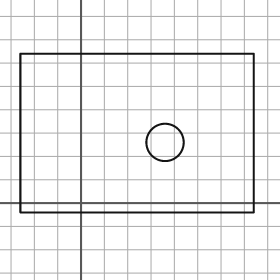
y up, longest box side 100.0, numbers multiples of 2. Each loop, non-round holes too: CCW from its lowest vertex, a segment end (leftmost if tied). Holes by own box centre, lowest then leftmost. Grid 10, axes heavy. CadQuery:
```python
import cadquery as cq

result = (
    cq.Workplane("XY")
    .moveTo(-26.0, -4.0)
    .lineTo(74.0, -4.0)
    .lineTo(74.0, 64.0)
    .lineTo(-26.0, 64.0)
    .close()
    .moveTo(36.0, 26.0)
    .circle(8.0)
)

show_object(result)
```